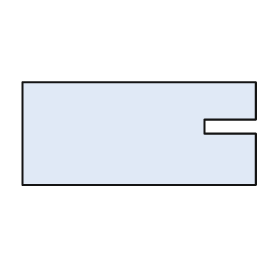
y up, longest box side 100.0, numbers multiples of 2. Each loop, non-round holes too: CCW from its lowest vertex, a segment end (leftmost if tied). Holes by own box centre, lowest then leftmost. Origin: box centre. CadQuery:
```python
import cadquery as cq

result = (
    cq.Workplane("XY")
    .moveTo(-50.0, -22.0)
    .lineTo(50.0, -22.0)
    .lineTo(50.0, 0.0)
    .lineTo(28.0, 0.0)
    .lineTo(28.0, 6.0)
    .lineTo(50.0, 6.0)
    .lineTo(50.0, 22.0)
    .lineTo(-50.0, 22.0)
    .close()
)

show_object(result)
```